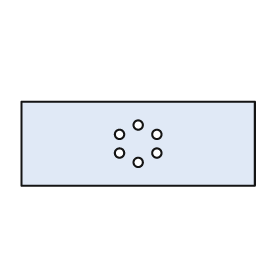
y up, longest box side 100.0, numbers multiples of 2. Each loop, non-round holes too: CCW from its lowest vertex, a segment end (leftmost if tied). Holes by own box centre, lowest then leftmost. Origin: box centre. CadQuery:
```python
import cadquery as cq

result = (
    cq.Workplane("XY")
    .moveTo(-50.0, -18.0)
    .lineTo(50.0, -18.0)
    .lineTo(50.0, 18.0)
    .lineTo(-50.0, 18.0)
    .close()
    .moveTo(0.0, -8.0)
    .circle(2.0)
    .moveTo(-8.0, -4.0)
    .circle(2.0)
    .moveTo(8.0, -4.0)
    .circle(2.0)
    .moveTo(-8.0, 4.0)
    .circle(2.0)
    .moveTo(8.0, 4.0)
    .circle(2.0)
    .moveTo(0.0, 8.0)
    .circle(2.0)
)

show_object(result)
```